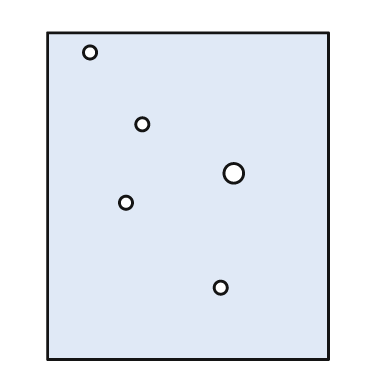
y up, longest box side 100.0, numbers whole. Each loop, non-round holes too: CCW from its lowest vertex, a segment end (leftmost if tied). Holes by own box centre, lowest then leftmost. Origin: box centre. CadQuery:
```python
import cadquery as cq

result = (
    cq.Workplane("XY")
    .moveTo(-43.0, -50.0)
    .lineTo(43.0, -50.0)
    .lineTo(43.0, 50.0)
    .lineTo(-43.0, 50.0)
    .close()
    .moveTo(10.0, -28.0)
    .circle(2.0)
    .moveTo(-19.0, -2.0)
    .circle(2.0)
    .moveTo(14.0, 7.0)
    .circle(3.0)
    .moveTo(-14.0, 22.0)
    .circle(2.0)
    .moveTo(-30.0, 44.0)
    .circle(2.0)
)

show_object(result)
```